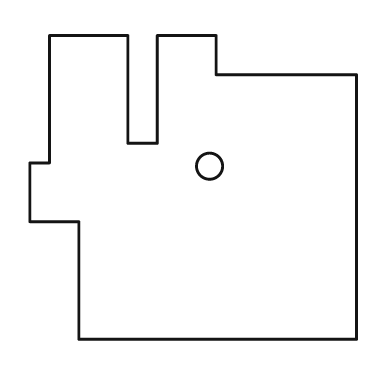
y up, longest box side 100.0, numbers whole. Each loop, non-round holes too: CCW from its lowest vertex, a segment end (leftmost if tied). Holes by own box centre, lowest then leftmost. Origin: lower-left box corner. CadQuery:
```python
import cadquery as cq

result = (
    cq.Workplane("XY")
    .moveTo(15.0, 0.0)
    .lineTo(100.0, 0.0)
    .lineTo(100.0, 81.0)
    .lineTo(57.0, 81.0)
    .lineTo(57.0, 93.0)
    .lineTo(39.0, 93.0)
    .lineTo(39.0, 60.0)
    .lineTo(30.0, 60.0)
    .lineTo(30.0, 93.0)
    .lineTo(6.0, 93.0)
    .lineTo(6.0, 54.0)
    .lineTo(0.0, 54.0)
    .lineTo(0.0, 36.0)
    .lineTo(15.0, 36.0)
    .close()
    .moveTo(55.0, 53.0)
    .circle(4.0)
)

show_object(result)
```